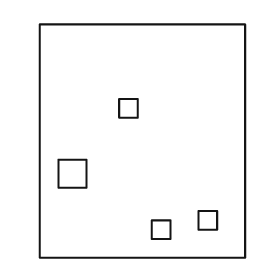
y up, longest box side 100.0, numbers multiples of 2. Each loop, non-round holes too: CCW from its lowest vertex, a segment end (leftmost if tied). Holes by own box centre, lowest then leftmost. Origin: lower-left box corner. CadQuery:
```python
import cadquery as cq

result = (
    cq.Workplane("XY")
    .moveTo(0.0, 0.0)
    .lineTo(88.0, 0.0)
    .lineTo(88.0, 100.0)
    .lineTo(0.0, 100.0)
    .close()
    .moveTo(48.0, 8.0)
    .lineTo(56.0, 8.0)
    .lineTo(56.0, 16.0)
    .lineTo(48.0, 16.0)
    .close()
    .moveTo(68.0, 12.0)
    .lineTo(76.0, 12.0)
    .lineTo(76.0, 20.0)
    .lineTo(68.0, 20.0)
    .close()
    .moveTo(8.0, 30.0)
    .lineTo(20.0, 30.0)
    .lineTo(20.0, 42.0)
    .lineTo(8.0, 42.0)
    .close()
    .moveTo(34.0, 60.0)
    .lineTo(42.0, 60.0)
    .lineTo(42.0, 68.0)
    .lineTo(34.0, 68.0)
    .close()
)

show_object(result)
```